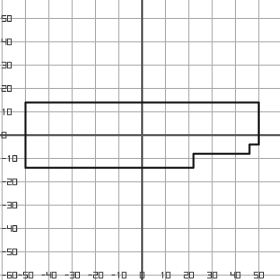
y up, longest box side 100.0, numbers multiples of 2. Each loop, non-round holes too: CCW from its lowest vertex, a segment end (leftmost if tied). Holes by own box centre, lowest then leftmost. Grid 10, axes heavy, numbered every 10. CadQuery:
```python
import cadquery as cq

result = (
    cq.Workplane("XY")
    .moveTo(-50.0, -14.0)
    .lineTo(22.0, -14.0)
    .lineTo(22.0, -8.0)
    .lineTo(46.0, -8.0)
    .lineTo(46.0, -4.0)
    .lineTo(50.0, -4.0)
    .lineTo(50.0, 14.0)
    .lineTo(-50.0, 14.0)
    .close()
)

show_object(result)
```